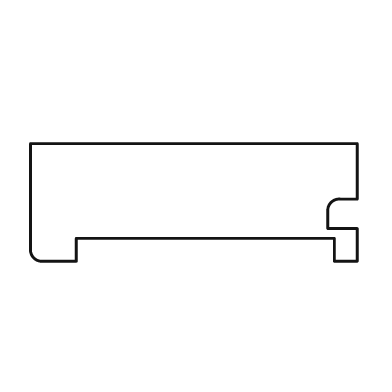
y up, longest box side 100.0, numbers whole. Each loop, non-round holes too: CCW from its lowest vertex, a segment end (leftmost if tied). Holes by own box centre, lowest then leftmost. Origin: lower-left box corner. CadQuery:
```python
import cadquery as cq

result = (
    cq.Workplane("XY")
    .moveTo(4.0, 0.0)
    .lineTo(14.0, 0.0)
    .lineTo(14.0, 7.0)
    .lineTo(93.0, 7.0)
    .lineTo(93.0, 0.0)
    .lineTo(100.0, 0.0)
    .lineTo(100.0, 10.0)
    .lineTo(91.0, 10.0)
    .lineTo(91.0, 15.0)
    .threePointArc((92.0, 18.0), (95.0, 19.0))
    .lineTo(100.0, 19.0)
    .lineTo(100.0, 36.0)
    .lineTo(0.0, 36.0)
    .lineTo(0.0, 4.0)
    .threePointArc((1.0, 1.0), (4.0, 0.0))
    .close()
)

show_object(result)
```